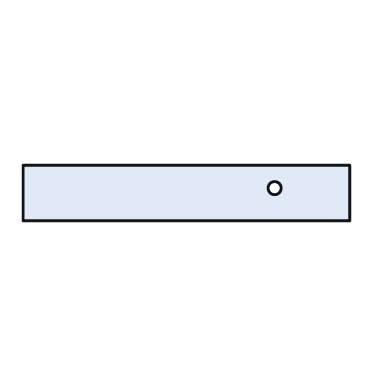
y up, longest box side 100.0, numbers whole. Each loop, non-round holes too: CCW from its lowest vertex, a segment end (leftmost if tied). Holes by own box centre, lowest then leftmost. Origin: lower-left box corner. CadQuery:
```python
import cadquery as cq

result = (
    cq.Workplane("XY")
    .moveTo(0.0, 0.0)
    .lineTo(100.0, 0.0)
    .lineTo(100.0, 17.0)
    .lineTo(0.0, 17.0)
    .close()
    .moveTo(77.0, 10.0)
    .circle(2.0)
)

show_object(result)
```